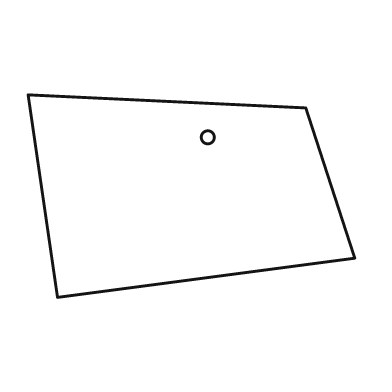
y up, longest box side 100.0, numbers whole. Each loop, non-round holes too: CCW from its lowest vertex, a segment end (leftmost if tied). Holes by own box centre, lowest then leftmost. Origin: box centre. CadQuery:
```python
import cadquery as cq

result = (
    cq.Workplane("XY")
    .moveTo(-41.0, -31.0)
    .lineTo(50.0, -19.0)
    .lineTo(35.0, 27.0)
    .lineTo(-50.0, 31.0)
    .close()
    .moveTo(5.0, 18.0)
    .circle(2.0)
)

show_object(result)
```